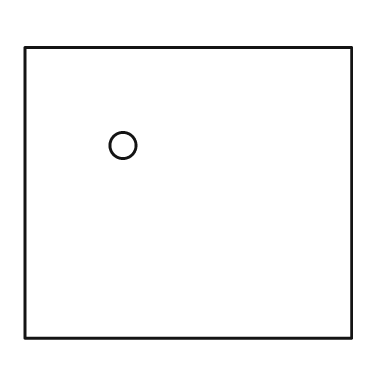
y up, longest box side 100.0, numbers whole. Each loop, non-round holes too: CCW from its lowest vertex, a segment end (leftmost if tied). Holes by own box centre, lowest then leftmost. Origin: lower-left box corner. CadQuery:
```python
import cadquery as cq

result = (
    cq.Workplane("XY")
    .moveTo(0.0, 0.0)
    .lineTo(100.0, 0.0)
    .lineTo(100.0, 89.0)
    .lineTo(0.0, 89.0)
    .close()
    .moveTo(30.0, 59.0)
    .circle(4.0)
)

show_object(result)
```